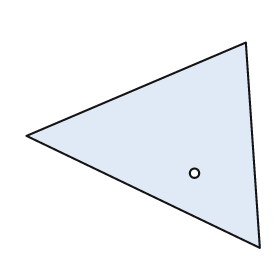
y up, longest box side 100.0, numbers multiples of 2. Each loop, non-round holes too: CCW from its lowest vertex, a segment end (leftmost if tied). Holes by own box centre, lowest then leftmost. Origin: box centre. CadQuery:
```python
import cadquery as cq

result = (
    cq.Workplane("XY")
    .moveTo(50.0, -44.0)
    .lineTo(44.0, 44.0)
    .lineTo(-50.0, 4.0)
    .close()
    .moveTo(22.0, -12.0)
    .circle(2.0)
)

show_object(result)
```